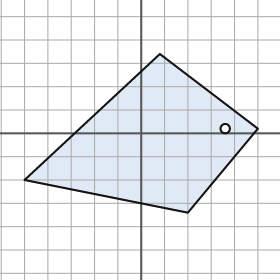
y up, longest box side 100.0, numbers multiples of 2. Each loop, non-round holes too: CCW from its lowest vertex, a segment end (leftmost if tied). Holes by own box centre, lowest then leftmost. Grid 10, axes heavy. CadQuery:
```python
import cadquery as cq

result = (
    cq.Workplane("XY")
    .moveTo(20.0, -34.0)
    .lineTo(50.0, 2.0)
    .lineTo(8.0, 34.0)
    .lineTo(-50.0, -20.0)
    .close()
    .moveTo(36.0, 2.0)
    .circle(2.0)
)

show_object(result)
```